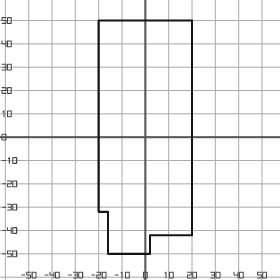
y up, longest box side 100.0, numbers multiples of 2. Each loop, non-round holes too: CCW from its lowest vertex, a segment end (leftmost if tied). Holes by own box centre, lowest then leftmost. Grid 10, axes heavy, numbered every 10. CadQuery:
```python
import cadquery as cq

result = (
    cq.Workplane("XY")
    .moveTo(-16.0, -50.0)
    .lineTo(2.0, -50.0)
    .lineTo(2.0, -42.0)
    .lineTo(20.0, -42.0)
    .lineTo(20.0, 50.0)
    .lineTo(-20.0, 50.0)
    .lineTo(-20.0, -32.0)
    .lineTo(-16.0, -32.0)
    .close()
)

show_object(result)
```